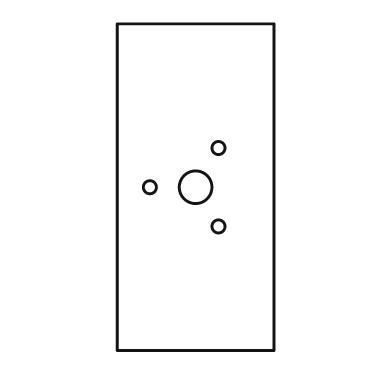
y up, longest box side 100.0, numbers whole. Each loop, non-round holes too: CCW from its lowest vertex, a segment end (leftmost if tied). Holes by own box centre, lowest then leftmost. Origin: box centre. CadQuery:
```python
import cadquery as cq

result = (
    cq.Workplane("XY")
    .moveTo(-24.0, -50.0)
    .lineTo(24.0, -50.0)
    .lineTo(24.0, 50.0)
    .lineTo(-24.0, 50.0)
    .close()
    .moveTo(7.0, -12.0)
    .circle(2.0)
    .moveTo(-14.0, 0.0)
    .circle(2.0)
    .moveTo(0.0, 0.0)
    .circle(5.0)
    .moveTo(7.0, 12.0)
    .circle(2.0)
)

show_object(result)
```